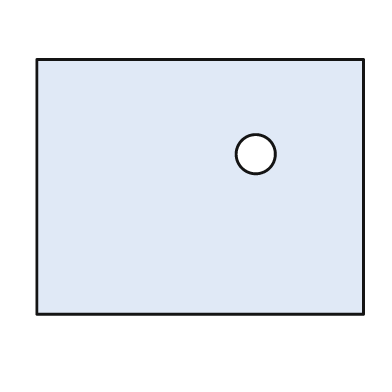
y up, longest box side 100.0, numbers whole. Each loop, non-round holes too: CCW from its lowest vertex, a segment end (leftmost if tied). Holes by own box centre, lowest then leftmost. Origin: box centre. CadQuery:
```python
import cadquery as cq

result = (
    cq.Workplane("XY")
    .moveTo(-50.0, -39.0)
    .lineTo(50.0, -39.0)
    .lineTo(50.0, 39.0)
    .lineTo(-50.0, 39.0)
    .close()
    .moveTo(17.0, 10.0)
    .circle(6.0)
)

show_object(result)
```